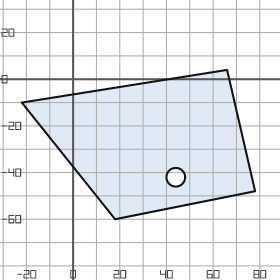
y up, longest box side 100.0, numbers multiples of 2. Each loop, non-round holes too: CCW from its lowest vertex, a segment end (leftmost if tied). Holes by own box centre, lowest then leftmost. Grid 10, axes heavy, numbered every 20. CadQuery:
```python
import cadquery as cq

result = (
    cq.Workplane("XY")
    .moveTo(18.0, -60.0)
    .lineTo(78.0, -48.0)
    .lineTo(66.0, 4.0)
    .lineTo(-22.0, -10.0)
    .close()
    .moveTo(44.0, -42.0)
    .circle(4.0)
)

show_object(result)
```